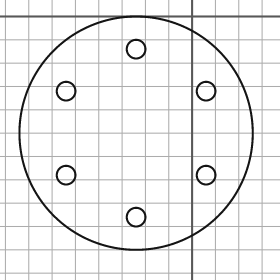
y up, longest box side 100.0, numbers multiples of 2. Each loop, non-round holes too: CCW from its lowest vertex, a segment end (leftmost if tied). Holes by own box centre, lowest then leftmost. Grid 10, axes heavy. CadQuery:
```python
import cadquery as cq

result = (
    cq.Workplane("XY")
    .moveTo(-24.0, -50.0)
    .circle(50.0)
    .moveTo(-24.0, -86.0)
    .circle(4.0)
    .moveTo(-54.0, -68.0)
    .circle(4.0)
    .moveTo(6.0, -68.0)
    .circle(4.0)
    .moveTo(-54.0, -32.0)
    .circle(4.0)
    .moveTo(6.0, -32.0)
    .circle(4.0)
    .moveTo(-24.0, -14.0)
    .circle(4.0)
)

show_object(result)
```